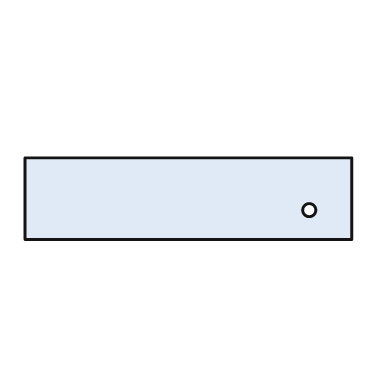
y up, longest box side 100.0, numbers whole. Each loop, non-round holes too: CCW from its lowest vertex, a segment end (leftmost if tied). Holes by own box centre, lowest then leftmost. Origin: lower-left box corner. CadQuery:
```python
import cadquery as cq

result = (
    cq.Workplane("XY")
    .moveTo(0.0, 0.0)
    .lineTo(100.0, 0.0)
    .lineTo(100.0, 25.0)
    .lineTo(0.0, 25.0)
    .close()
    .moveTo(87.0, 9.0)
    .circle(2.0)
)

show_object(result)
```